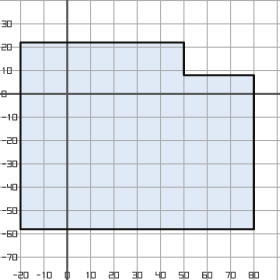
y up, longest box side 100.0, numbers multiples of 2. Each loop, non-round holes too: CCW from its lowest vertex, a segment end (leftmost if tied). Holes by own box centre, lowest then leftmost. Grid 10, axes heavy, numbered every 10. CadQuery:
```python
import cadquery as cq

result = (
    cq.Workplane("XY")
    .moveTo(-20.0, -58.0)
    .lineTo(80.0, -58.0)
    .lineTo(80.0, 8.0)
    .lineTo(50.0, 8.0)
    .lineTo(50.0, 22.0)
    .lineTo(-20.0, 22.0)
    .close()
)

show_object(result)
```